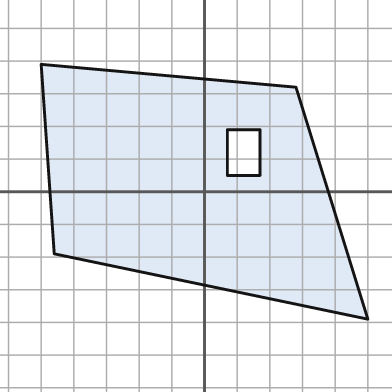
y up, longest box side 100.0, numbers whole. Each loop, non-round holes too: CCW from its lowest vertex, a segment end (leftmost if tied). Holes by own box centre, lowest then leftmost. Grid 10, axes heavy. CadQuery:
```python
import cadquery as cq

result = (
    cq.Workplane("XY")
    .moveTo(50.0, -39.0)
    .lineTo(28.0, 32.0)
    .lineTo(-50.0, 39.0)
    .lineTo(-46.0, -19.0)
    .close()
    .moveTo(7.0, 5.0)
    .lineTo(17.0, 5.0)
    .lineTo(17.0, 19.0)
    .lineTo(7.0, 19.0)
    .close()
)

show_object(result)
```